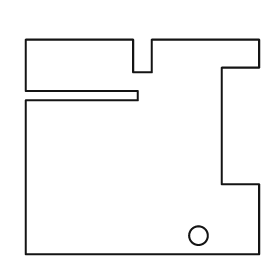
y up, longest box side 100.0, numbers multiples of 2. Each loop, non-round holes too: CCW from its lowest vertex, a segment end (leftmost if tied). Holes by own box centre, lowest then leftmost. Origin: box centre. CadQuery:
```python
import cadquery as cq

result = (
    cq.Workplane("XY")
    .moveTo(-50.0, -46.0)
    .lineTo(50.0, -46.0)
    .lineTo(50.0, -16.0)
    .lineTo(34.0, -16.0)
    .lineTo(34.0, 34.0)
    .lineTo(50.0, 34.0)
    .lineTo(50.0, 46.0)
    .lineTo(4.0, 46.0)
    .lineTo(4.0, 32.0)
    .lineTo(-4.0, 32.0)
    .lineTo(-4.0, 46.0)
    .lineTo(-50.0, 46.0)
    .lineTo(-50.0, 24.0)
    .lineTo(-2.0, 24.0)
    .lineTo(-2.0, 20.0)
    .lineTo(-50.0, 20.0)
    .close()
    .moveTo(24.0, -38.0)
    .circle(4.0)
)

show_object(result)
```